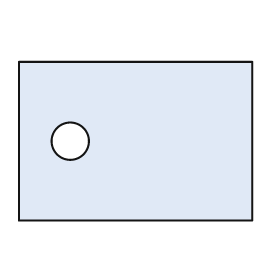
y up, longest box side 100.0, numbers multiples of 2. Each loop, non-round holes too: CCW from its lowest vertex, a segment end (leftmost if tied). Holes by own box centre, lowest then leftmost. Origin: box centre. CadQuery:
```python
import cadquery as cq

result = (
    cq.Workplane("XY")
    .moveTo(-50.0, -34.0)
    .lineTo(50.0, -34.0)
    .lineTo(50.0, 34.0)
    .lineTo(-50.0, 34.0)
    .close()
    .moveTo(-28.0, 0.0)
    .circle(8.0)
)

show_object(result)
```